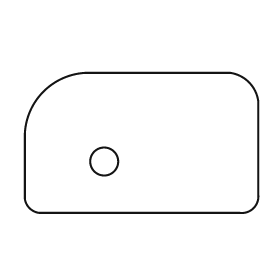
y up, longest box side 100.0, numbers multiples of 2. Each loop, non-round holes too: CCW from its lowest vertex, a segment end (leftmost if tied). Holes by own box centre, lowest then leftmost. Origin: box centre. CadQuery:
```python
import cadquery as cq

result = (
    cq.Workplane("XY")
    .moveTo(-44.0, -30.0)
    .lineTo(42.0, -30.0)
    .threePointArc((48.0, -28.0), (50.0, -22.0))
    .lineTo(50.0, 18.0)
    .threePointArc((46.0, 26.0), (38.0, 30.0))
    .lineTo(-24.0, 30.0)
    .threePointArc((-42.0, 22.0), (-50.0, 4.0))
    .lineTo(-50.0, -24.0)
    .threePointArc((-48.0, -28.0), (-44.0, -30.0))
    .close()
    .moveTo(-16.0, -8.0)
    .circle(6.0)
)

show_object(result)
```